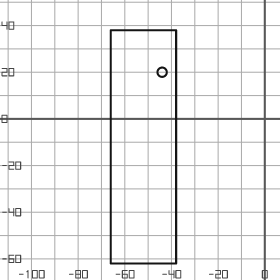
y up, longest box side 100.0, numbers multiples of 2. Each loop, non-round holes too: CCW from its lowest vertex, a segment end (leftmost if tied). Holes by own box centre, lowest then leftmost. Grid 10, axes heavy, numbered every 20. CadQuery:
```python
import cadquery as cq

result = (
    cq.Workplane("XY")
    .moveTo(-66.0, -62.0)
    .lineTo(-38.0, -62.0)
    .lineTo(-38.0, 38.0)
    .lineTo(-66.0, 38.0)
    .close()
    .moveTo(-44.0, 20.0)
    .circle(2.0)
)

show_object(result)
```